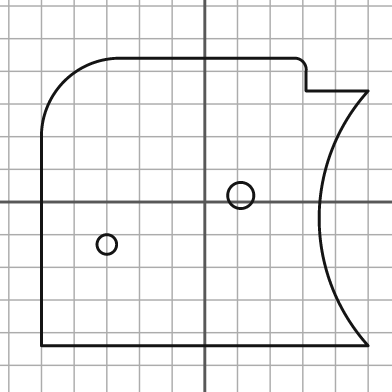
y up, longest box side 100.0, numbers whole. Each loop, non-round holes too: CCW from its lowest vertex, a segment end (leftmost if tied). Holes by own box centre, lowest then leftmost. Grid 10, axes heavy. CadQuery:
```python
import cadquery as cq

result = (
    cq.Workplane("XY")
    .moveTo(-50.0, -44.0)
    .lineTo(50.0, -44.0)
    .threePointArc((35.0, -5.0), (50.0, 34.0))
    .lineTo(31.0, 34.0)
    .lineTo(31.0, 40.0)
    .threePointArc((30.0, 43.0), (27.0, 44.0))
    .lineTo(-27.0, 44.0)
    .threePointArc((-43.0, 37.0), (-50.0, 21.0))
    .close()
    .moveTo(-30.0, -13.0)
    .circle(3.0)
    .moveTo(11.0, 2.0)
    .circle(4.0)
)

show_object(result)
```